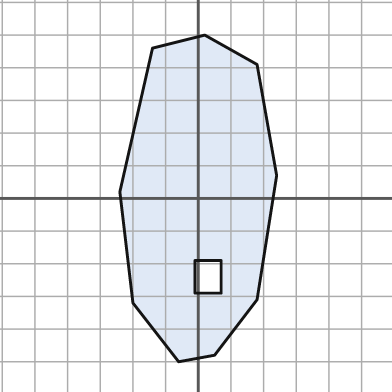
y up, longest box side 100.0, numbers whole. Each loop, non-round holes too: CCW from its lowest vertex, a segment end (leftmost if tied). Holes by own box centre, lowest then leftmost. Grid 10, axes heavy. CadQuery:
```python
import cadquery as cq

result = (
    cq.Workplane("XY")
    .moveTo(-6.0, -50.0)
    .lineTo(5.0, -48.0)
    .lineTo(18.0, -31.0)
    .lineTo(24.0, 7.0)
    .lineTo(18.0, 41.0)
    .lineTo(2.0, 50.0)
    .lineTo(-14.0, 46.0)
    .lineTo(-24.0, 2.0)
    .lineTo(-20.0, -32.0)
    .close()
    .moveTo(-1.0, -29.0)
    .lineTo(7.0, -29.0)
    .lineTo(7.0, -19.0)
    .lineTo(-1.0, -19.0)
    .close()
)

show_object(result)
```